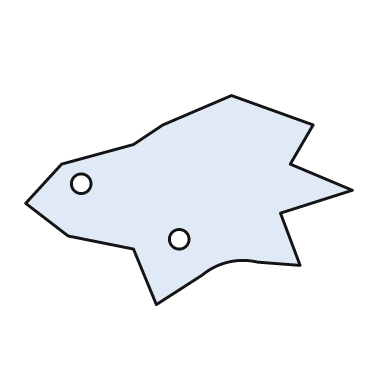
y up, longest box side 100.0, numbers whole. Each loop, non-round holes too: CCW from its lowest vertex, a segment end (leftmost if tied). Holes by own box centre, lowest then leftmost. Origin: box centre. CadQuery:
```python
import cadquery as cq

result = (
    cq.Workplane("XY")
    .moveTo(-10.0, -32.0)
    .lineTo(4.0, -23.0)
    .threePointArc((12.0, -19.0), (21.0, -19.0))
    .lineTo(34.0, -20.0)
    .lineTo(28.0, -4.0)
    .lineTo(50.0, 3.0)
    .lineTo(31.0, 11.0)
    .lineTo(38.0, 23.0)
    .lineTo(13.0, 32.0)
    .lineTo(-8.0, 23.0)
    .lineTo(-17.0, 17.0)
    .lineTo(-39.0, 11.0)
    .lineTo(-50.0, -1.0)
    .lineTo(-37.0, -11.0)
    .lineTo(-17.0, -15.0)
    .close()
    .moveTo(-3.0, -12.0)
    .circle(3.0)
    .moveTo(-33.0, 5.0)
    .circle(3.0)
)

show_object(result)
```